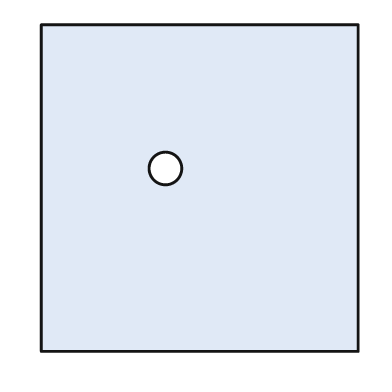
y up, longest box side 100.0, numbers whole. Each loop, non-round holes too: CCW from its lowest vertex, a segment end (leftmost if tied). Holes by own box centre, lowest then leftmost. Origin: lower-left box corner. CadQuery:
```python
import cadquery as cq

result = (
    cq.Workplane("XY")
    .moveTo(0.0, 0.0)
    .lineTo(97.0, 0.0)
    .lineTo(97.0, 100.0)
    .lineTo(0.0, 100.0)
    .close()
    .moveTo(38.0, 56.0)
    .circle(5.0)
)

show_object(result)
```